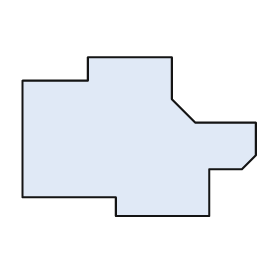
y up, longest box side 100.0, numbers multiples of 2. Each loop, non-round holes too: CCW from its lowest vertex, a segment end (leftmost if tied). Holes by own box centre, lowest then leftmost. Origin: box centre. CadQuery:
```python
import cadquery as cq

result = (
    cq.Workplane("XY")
    .moveTo(-10.0, -34.0)
    .lineTo(30.0, -34.0)
    .lineTo(30.0, -14.0)
    .lineTo(44.0, -14.0)
    .lineTo(50.0, -8.0)
    .lineTo(50.0, 6.0)
    .lineTo(24.0, 6.0)
    .lineTo(14.0, 16.0)
    .lineTo(14.0, 34.0)
    .lineTo(-22.0, 34.0)
    .lineTo(-22.0, 24.0)
    .lineTo(-50.0, 24.0)
    .lineTo(-50.0, -26.0)
    .lineTo(-10.0, -26.0)
    .close()
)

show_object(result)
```